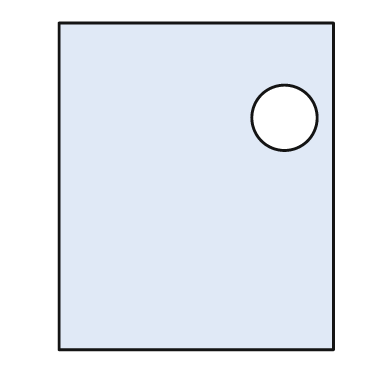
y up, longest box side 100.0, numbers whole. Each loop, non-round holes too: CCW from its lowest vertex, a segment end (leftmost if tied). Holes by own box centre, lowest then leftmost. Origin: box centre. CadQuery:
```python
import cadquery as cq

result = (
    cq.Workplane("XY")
    .moveTo(-42.0, -50.0)
    .lineTo(42.0, -50.0)
    .lineTo(42.0, 50.0)
    .lineTo(-42.0, 50.0)
    .close()
    .moveTo(27.0, 21.0)
    .circle(10.0)
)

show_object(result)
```